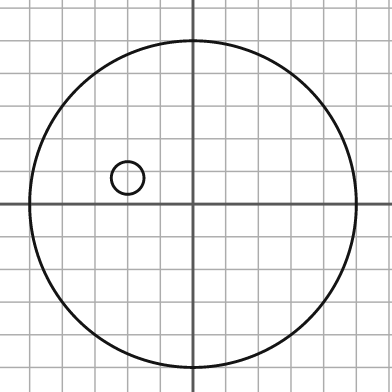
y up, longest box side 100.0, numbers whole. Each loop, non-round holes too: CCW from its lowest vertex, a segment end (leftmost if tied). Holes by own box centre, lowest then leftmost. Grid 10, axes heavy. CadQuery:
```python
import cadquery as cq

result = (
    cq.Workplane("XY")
    .moveTo(0.0, 0.0)
    .circle(50.0)
    .moveTo(-20.0, 8.0)
    .circle(5.0)
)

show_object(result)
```